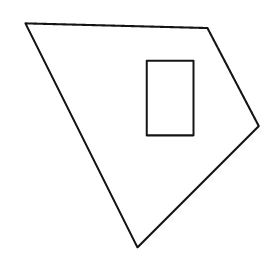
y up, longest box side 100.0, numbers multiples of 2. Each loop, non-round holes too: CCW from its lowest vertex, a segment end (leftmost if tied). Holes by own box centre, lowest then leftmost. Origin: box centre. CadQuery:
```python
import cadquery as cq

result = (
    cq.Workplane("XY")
    .moveTo(-2.0, -48.0)
    .lineTo(50.0, 4.0)
    .lineTo(28.0, 46.0)
    .lineTo(-50.0, 48.0)
    .close()
    .moveTo(2.0, 0.0)
    .lineTo(22.0, 0.0)
    .lineTo(22.0, 32.0)
    .lineTo(2.0, 32.0)
    .close()
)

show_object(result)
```